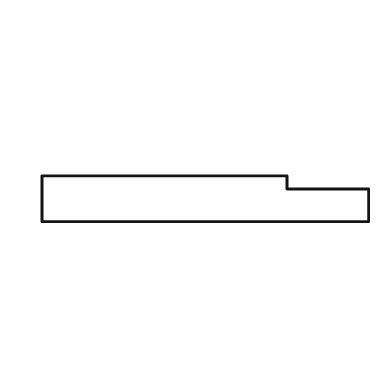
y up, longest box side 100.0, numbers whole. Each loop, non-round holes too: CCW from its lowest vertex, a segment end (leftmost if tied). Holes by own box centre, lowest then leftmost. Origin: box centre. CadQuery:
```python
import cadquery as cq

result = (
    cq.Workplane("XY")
    .moveTo(-50.0, -7.0)
    .lineTo(50.0, -7.0)
    .lineTo(50.0, 3.0)
    .lineTo(25.0, 3.0)
    .lineTo(25.0, 7.0)
    .lineTo(-50.0, 7.0)
    .close()
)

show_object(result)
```